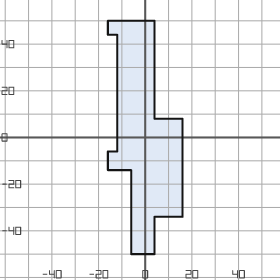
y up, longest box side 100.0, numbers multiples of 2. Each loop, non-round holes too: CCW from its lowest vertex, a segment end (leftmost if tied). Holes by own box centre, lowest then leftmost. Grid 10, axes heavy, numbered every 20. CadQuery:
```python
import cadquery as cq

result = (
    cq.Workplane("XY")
    .moveTo(-6.0, -50.0)
    .lineTo(4.0, -50.0)
    .lineTo(4.0, -34.0)
    .lineTo(16.0, -34.0)
    .lineTo(16.0, 8.0)
    .lineTo(4.0, 8.0)
    .lineTo(4.0, 50.0)
    .lineTo(-16.0, 50.0)
    .lineTo(-16.0, 44.0)
    .lineTo(-12.0, 44.0)
    .lineTo(-12.0, -6.0)
    .lineTo(-16.0, -6.0)
    .lineTo(-16.0, -14.0)
    .lineTo(-6.0, -14.0)
    .close()
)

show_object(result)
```